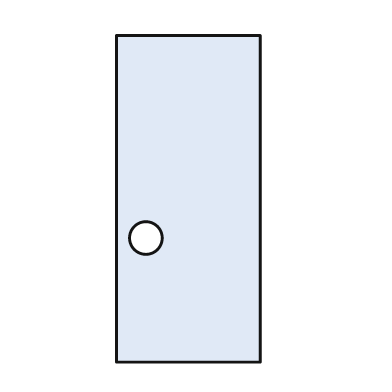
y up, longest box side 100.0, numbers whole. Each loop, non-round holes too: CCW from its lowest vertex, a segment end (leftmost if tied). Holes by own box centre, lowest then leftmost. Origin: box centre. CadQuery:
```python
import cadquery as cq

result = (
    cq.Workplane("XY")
    .moveTo(-22.0, -50.0)
    .lineTo(22.0, -50.0)
    .lineTo(22.0, 50.0)
    .lineTo(-22.0, 50.0)
    .close()
    .moveTo(-13.0, -12.0)
    .circle(5.0)
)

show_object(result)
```